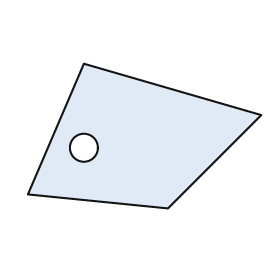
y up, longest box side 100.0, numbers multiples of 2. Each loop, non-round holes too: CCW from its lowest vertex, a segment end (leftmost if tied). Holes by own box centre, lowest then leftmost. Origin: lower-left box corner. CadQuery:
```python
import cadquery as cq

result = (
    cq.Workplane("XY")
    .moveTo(60.0, 0.0)
    .lineTo(100.0, 40.0)
    .lineTo(24.0, 62.0)
    .lineTo(0.0, 6.0)
    .close()
    .moveTo(24.0, 26.0)
    .circle(6.0)
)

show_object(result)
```